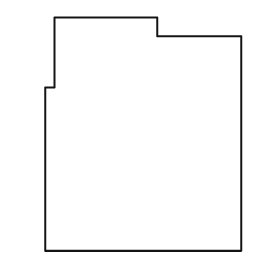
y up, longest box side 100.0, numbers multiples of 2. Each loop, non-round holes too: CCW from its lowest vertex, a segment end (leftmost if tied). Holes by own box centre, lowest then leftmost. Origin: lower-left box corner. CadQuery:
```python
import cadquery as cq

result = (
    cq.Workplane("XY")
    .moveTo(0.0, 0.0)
    .lineTo(84.0, 0.0)
    .lineTo(84.0, 92.0)
    .lineTo(48.0, 92.0)
    .lineTo(48.0, 100.0)
    .lineTo(4.0, 100.0)
    .lineTo(4.0, 70.0)
    .lineTo(0.0, 70.0)
    .close()
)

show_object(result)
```